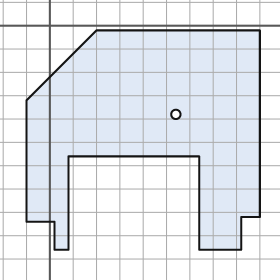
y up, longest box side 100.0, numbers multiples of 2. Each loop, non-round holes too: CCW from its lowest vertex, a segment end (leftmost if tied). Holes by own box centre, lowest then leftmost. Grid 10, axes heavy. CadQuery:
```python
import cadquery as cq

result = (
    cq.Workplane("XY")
    .moveTo(2.0, -96.0)
    .lineTo(8.0, -96.0)
    .lineTo(8.0, -56.0)
    .lineTo(64.0, -56.0)
    .lineTo(64.0, -96.0)
    .lineTo(82.0, -96.0)
    .lineTo(82.0, -82.0)
    .lineTo(90.0, -82.0)
    .lineTo(90.0, -2.0)
    .lineTo(20.0, -2.0)
    .lineTo(-10.0, -32.0)
    .lineTo(-10.0, -84.0)
    .lineTo(2.0, -84.0)
    .close()
    .moveTo(54.0, -38.0)
    .circle(2.0)
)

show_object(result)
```